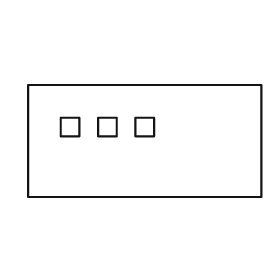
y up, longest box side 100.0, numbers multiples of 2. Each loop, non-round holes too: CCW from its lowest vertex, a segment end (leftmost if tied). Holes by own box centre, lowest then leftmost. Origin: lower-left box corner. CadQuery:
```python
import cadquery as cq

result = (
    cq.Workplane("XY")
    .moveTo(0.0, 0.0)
    .lineTo(100.0, 0.0)
    .lineTo(100.0, 48.0)
    .lineTo(0.0, 48.0)
    .close()
    .moveTo(14.0, 26.0)
    .lineTo(22.0, 26.0)
    .lineTo(22.0, 34.0)
    .lineTo(14.0, 34.0)
    .close()
    .moveTo(30.0, 26.0)
    .lineTo(38.0, 26.0)
    .lineTo(38.0, 34.0)
    .lineTo(30.0, 34.0)
    .close()
    .moveTo(46.0, 26.0)
    .lineTo(54.0, 26.0)
    .lineTo(54.0, 34.0)
    .lineTo(46.0, 34.0)
    .close()
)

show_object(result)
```